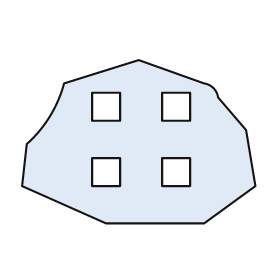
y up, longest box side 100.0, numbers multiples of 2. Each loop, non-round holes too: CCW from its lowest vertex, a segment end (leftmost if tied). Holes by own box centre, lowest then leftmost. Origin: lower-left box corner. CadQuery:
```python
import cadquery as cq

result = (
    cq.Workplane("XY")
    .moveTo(36.0, 0.0)
    .lineTo(78.0, 0.0)
    .lineTo(100.0, 16.0)
    .lineTo(96.0, 40.0)
    .lineTo(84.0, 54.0)
    .threePointArc((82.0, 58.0), (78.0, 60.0))
    .lineTo(50.0, 70.0)
    .lineTo(18.0, 60.0)
    .threePointArc((12.0, 46.0), (2.0, 34.0))
    .lineTo(0.0, 16.0)
    .close()
    .moveTo(30.0, 16.0)
    .lineTo(42.0, 16.0)
    .lineTo(42.0, 28.0)
    .lineTo(30.0, 28.0)
    .close()
    .moveTo(60.0, 16.0)
    .lineTo(72.0, 16.0)
    .lineTo(72.0, 28.0)
    .lineTo(60.0, 28.0)
    .close()
    .moveTo(30.0, 44.0)
    .lineTo(42.0, 44.0)
    .lineTo(42.0, 56.0)
    .lineTo(30.0, 56.0)
    .close()
    .moveTo(60.0, 44.0)
    .lineTo(72.0, 44.0)
    .lineTo(72.0, 56.0)
    .lineTo(60.0, 56.0)
    .close()
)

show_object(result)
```